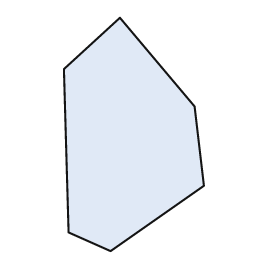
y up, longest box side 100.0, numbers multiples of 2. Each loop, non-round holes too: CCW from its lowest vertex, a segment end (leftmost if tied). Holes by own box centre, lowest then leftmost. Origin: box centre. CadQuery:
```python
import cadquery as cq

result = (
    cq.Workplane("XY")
    .moveTo(-10.0, -50.0)
    .lineTo(30.0, -22.0)
    .lineTo(26.0, 12.0)
    .lineTo(-6.0, 50.0)
    .lineTo(-30.0, 28.0)
    .lineTo(-28.0, -42.0)
    .close()
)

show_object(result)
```